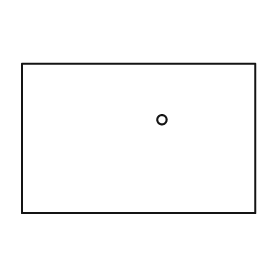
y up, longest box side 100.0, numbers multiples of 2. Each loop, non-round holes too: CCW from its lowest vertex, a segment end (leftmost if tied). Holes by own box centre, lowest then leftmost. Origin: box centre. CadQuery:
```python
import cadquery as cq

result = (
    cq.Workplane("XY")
    .moveTo(-50.0, -32.0)
    .lineTo(50.0, -32.0)
    .lineTo(50.0, 32.0)
    .lineTo(-50.0, 32.0)
    .close()
    .moveTo(10.0, 8.0)
    .circle(2.0)
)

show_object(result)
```